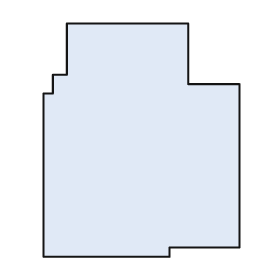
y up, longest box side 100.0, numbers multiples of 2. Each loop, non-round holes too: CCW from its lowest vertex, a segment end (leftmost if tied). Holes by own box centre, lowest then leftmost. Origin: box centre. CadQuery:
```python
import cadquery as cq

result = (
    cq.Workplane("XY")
    .moveTo(-42.0, -50.0)
    .lineTo(12.0, -50.0)
    .lineTo(12.0, -46.0)
    .lineTo(42.0, -46.0)
    .lineTo(42.0, 24.0)
    .lineTo(20.0, 24.0)
    .lineTo(20.0, 50.0)
    .lineTo(-32.0, 50.0)
    .lineTo(-32.0, 28.0)
    .lineTo(-38.0, 28.0)
    .lineTo(-38.0, 20.0)
    .lineTo(-42.0, 20.0)
    .close()
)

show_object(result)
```